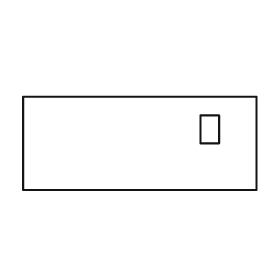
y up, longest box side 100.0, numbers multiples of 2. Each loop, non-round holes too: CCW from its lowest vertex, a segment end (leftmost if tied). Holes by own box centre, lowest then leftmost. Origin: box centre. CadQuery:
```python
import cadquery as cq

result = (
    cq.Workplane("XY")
    .moveTo(-50.0, -20.0)
    .lineTo(50.0, -20.0)
    .lineTo(50.0, 20.0)
    .lineTo(-50.0, 20.0)
    .close()
    .moveTo(26.0, 0.0)
    .lineTo(34.0, 0.0)
    .lineTo(34.0, 12.0)
    .lineTo(26.0, 12.0)
    .close()
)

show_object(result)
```